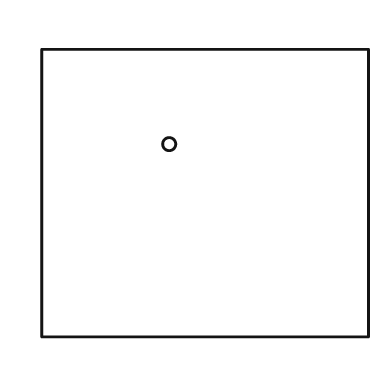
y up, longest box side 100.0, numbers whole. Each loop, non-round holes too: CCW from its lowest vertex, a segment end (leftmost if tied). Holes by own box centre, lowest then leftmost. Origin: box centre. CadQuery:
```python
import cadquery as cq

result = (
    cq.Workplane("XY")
    .moveTo(-50.0, -44.0)
    .lineTo(50.0, -44.0)
    .lineTo(50.0, 44.0)
    .lineTo(-50.0, 44.0)
    .close()
    .moveTo(-11.0, 15.0)
    .circle(2.0)
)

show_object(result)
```